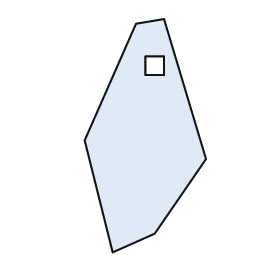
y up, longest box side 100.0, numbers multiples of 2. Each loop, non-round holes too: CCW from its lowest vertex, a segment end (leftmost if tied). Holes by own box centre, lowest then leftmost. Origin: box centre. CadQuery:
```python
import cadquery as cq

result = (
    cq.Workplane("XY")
    .moveTo(-14.0, -50.0)
    .lineTo(4.0, -42.0)
    .lineTo(26.0, -10.0)
    .lineTo(8.0, 50.0)
    .lineTo(-4.0, 48.0)
    .lineTo(-26.0, -2.0)
    .close()
    .moveTo(0.0, 26.0)
    .lineTo(8.0, 26.0)
    .lineTo(8.0, 34.0)
    .lineTo(0.0, 34.0)
    .close()
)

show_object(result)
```